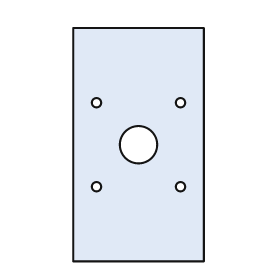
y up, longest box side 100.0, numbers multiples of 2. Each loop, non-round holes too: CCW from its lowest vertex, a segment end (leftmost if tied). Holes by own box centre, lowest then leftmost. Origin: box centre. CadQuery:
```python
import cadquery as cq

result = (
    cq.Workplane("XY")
    .moveTo(-28.0, -50.0)
    .lineTo(28.0, -50.0)
    .lineTo(28.0, 50.0)
    .lineTo(-28.0, 50.0)
    .close()
    .moveTo(-18.0, -18.0)
    .circle(2.0)
    .moveTo(18.0, -18.0)
    .circle(2.0)
    .moveTo(0.0, 0.0)
    .circle(8.0)
    .moveTo(-18.0, 18.0)
    .circle(2.0)
    .moveTo(18.0, 18.0)
    .circle(2.0)
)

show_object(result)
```